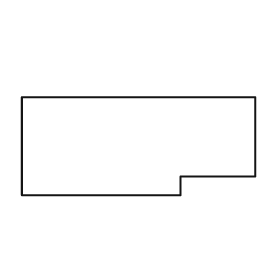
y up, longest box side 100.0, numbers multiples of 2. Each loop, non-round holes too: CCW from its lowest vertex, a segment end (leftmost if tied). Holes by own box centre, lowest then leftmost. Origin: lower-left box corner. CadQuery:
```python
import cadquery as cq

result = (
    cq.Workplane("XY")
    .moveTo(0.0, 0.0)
    .lineTo(68.0, 0.0)
    .lineTo(68.0, 8.0)
    .lineTo(100.0, 8.0)
    .lineTo(100.0, 42.0)
    .lineTo(0.0, 42.0)
    .close()
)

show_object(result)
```